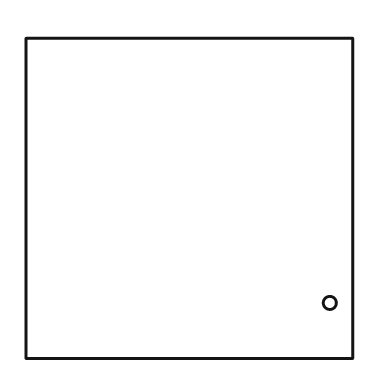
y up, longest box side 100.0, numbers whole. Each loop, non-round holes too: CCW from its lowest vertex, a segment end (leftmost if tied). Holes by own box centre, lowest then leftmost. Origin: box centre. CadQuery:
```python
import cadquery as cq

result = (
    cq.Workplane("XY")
    .moveTo(-50.0, -49.0)
    .lineTo(50.0, -49.0)
    .lineTo(50.0, 49.0)
    .lineTo(-50.0, 49.0)
    .close()
    .moveTo(43.0, -32.0)
    .circle(2.0)
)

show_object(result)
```